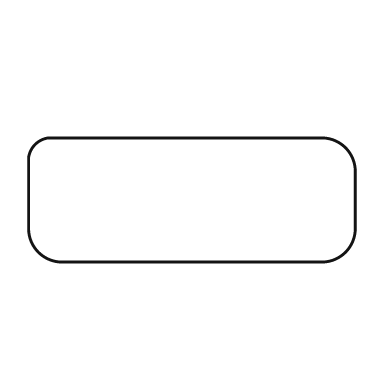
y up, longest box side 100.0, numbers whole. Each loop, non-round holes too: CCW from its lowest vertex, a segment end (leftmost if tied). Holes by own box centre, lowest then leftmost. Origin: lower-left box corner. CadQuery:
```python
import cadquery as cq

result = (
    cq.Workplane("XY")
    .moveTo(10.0, 0.0)
    .lineTo(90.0, 0.0)
    .threePointArc((97.0, 3.0), (100.0, 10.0))
    .lineTo(100.0, 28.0)
    .threePointArc((97.0, 35.0), (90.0, 38.0))
    .lineTo(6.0, 38.0)
    .threePointArc((2.0, 36.0), (0.0, 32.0))
    .lineTo(0.0, 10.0)
    .threePointArc((3.0, 3.0), (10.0, 0.0))
    .close()
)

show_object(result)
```